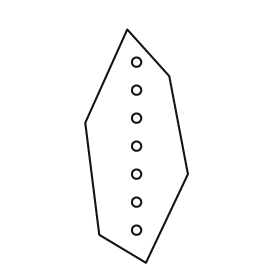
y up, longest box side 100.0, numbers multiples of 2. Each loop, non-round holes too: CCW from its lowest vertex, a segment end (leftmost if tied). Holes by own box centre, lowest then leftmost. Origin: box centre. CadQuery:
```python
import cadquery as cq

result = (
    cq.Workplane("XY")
    .moveTo(4.0, -50.0)
    .lineTo(22.0, -12.0)
    .lineTo(14.0, 30.0)
    .lineTo(-4.0, 50.0)
    .lineTo(-22.0, 10.0)
    .lineTo(-16.0, -38.0)
    .close()
    .moveTo(0.0, -36.0)
    .circle(2.0)
    .moveTo(0.0, -24.0)
    .circle(2.0)
    .moveTo(0.0, -12.0)
    .circle(2.0)
    .moveTo(0.0, 0.0)
    .circle(2.0)
    .moveTo(0.0, 12.0)
    .circle(2.0)
    .moveTo(0.0, 24.0)
    .circle(2.0)
    .moveTo(0.0, 36.0)
    .circle(2.0)
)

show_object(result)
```